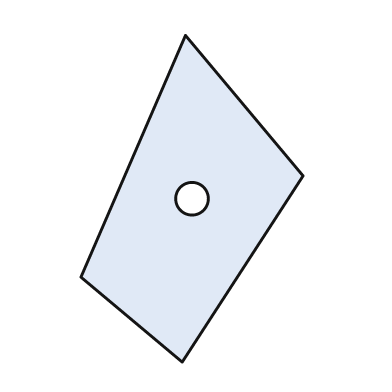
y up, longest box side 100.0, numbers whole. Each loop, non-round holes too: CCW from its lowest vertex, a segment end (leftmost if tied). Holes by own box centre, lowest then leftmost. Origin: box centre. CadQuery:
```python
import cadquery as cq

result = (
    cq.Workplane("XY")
    .moveTo(-3.0, -50.0)
    .lineTo(34.0, 7.0)
    .lineTo(-2.0, 50.0)
    .lineTo(-34.0, -24.0)
    .close()
    .moveTo(0.0, 0.0)
    .circle(5.0)
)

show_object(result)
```